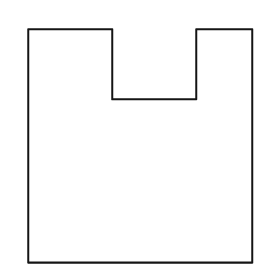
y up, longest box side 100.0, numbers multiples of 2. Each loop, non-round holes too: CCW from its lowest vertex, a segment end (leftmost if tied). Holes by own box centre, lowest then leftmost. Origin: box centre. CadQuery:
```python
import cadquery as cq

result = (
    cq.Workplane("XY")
    .moveTo(-48.0, -50.0)
    .lineTo(48.0, -50.0)
    .lineTo(48.0, 50.0)
    .lineTo(24.0, 50.0)
    .lineTo(24.0, 20.0)
    .lineTo(-12.0, 20.0)
    .lineTo(-12.0, 50.0)
    .lineTo(-48.0, 50.0)
    .close()
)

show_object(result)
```